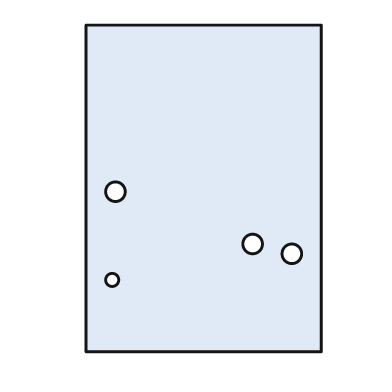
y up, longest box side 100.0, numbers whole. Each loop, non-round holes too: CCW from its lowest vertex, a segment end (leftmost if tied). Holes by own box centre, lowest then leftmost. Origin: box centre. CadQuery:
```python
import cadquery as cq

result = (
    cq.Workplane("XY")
    .moveTo(-36.0, -50.0)
    .lineTo(36.0, -50.0)
    .lineTo(36.0, 50.0)
    .lineTo(-36.0, 50.0)
    .close()
    .moveTo(-28.0, -28.0)
    .circle(2.0)
    .moveTo(27.0, -20.0)
    .circle(3.0)
    .moveTo(15.0, -17.0)
    .circle(3.0)
    .moveTo(-27.0, -1.0)
    .circle(3.0)
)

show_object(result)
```